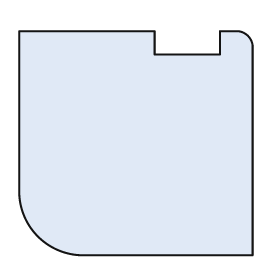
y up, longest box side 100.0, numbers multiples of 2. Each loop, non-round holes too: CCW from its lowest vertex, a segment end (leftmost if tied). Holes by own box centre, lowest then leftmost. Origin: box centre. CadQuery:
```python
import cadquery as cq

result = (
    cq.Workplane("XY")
    .moveTo(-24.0, -48.0)
    .lineTo(50.0, -48.0)
    .lineTo(50.0, 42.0)
    .threePointArc((48.0, 46.0), (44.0, 48.0))
    .lineTo(36.0, 48.0)
    .lineTo(36.0, 38.0)
    .lineTo(8.0, 38.0)
    .lineTo(8.0, 48.0)
    .lineTo(-50.0, 48.0)
    .lineTo(-50.0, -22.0)
    .threePointArc((-42.0, -40.0), (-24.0, -48.0))
    .close()
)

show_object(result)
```